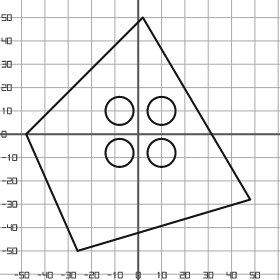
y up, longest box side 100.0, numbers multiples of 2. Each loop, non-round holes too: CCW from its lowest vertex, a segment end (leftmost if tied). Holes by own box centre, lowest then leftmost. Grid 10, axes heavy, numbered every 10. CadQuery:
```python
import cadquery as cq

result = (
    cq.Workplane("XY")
    .moveTo(-26.0, -50.0)
    .lineTo(48.0, -28.0)
    .lineTo(2.0, 50.0)
    .lineTo(-48.0, 0.0)
    .close()
    .moveTo(-8.0, -8.0)
    .circle(6.0)
    .moveTo(10.0, -8.0)
    .circle(6.0)
    .moveTo(-8.0, 10.0)
    .circle(6.0)
    .moveTo(10.0, 10.0)
    .circle(6.0)
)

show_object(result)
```